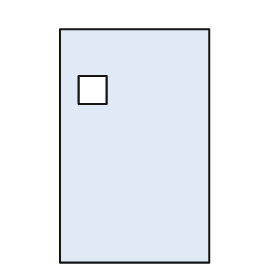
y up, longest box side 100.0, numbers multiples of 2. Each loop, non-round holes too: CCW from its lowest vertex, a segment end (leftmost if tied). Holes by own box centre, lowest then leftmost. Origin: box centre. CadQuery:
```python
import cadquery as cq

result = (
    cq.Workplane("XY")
    .moveTo(-32.0, -50.0)
    .lineTo(32.0, -50.0)
    .lineTo(32.0, 50.0)
    .lineTo(-32.0, 50.0)
    .close()
    .moveTo(-24.0, 18.0)
    .lineTo(-12.0, 18.0)
    .lineTo(-12.0, 30.0)
    .lineTo(-24.0, 30.0)
    .close()
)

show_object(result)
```